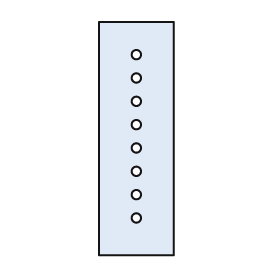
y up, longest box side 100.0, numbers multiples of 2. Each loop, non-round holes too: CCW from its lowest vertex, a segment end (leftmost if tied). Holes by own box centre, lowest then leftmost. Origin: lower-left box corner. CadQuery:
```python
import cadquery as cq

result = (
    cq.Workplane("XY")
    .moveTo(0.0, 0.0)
    .lineTo(32.0, 0.0)
    .lineTo(32.0, 100.0)
    .lineTo(0.0, 100.0)
    .close()
    .moveTo(16.0, 16.0)
    .circle(2.0)
    .moveTo(16.0, 26.0)
    .circle(2.0)
    .moveTo(16.0, 36.0)
    .circle(2.0)
    .moveTo(16.0, 46.0)
    .circle(2.0)
    .moveTo(16.0, 56.0)
    .circle(2.0)
    .moveTo(16.0, 66.0)
    .circle(2.0)
    .moveTo(16.0, 76.0)
    .circle(2.0)
    .moveTo(16.0, 86.0)
    .circle(2.0)
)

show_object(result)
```